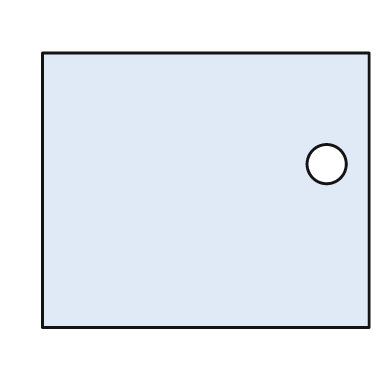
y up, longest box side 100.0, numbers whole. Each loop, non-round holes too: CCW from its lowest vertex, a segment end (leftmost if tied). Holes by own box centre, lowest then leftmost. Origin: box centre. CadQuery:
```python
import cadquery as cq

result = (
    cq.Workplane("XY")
    .moveTo(-50.0, -42.0)
    .lineTo(50.0, -42.0)
    .lineTo(50.0, 42.0)
    .lineTo(-50.0, 42.0)
    .close()
    .moveTo(37.0, 8.0)
    .circle(6.0)
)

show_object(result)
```